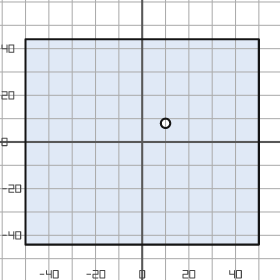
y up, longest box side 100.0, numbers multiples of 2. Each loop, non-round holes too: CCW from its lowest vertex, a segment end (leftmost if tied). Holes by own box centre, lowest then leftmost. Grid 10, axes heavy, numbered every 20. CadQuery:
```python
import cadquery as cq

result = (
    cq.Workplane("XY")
    .moveTo(-50.0, -44.0)
    .lineTo(50.0, -44.0)
    .lineTo(50.0, 44.0)
    .lineTo(-50.0, 44.0)
    .close()
    .moveTo(10.0, 8.0)
    .circle(2.0)
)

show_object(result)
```